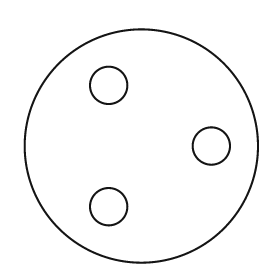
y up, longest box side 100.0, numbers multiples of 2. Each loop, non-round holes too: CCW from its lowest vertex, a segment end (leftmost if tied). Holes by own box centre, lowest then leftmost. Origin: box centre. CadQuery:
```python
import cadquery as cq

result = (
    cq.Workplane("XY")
    .moveTo(0.0, 0.0)
    .circle(50.0)
    .moveTo(-14.0, -26.0)
    .circle(8.0)
    .moveTo(30.0, 0.0)
    .circle(8.0)
    .moveTo(-14.0, 26.0)
    .circle(8.0)
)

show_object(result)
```